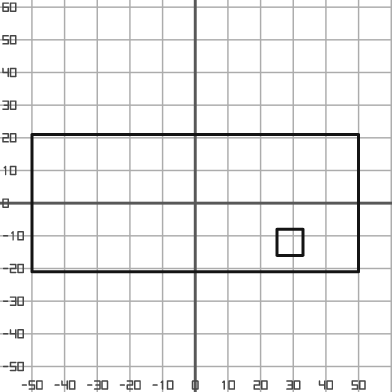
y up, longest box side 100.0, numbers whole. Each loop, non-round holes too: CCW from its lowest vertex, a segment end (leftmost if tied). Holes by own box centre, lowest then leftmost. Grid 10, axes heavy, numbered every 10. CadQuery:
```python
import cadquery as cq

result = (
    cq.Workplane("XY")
    .moveTo(-50.0, -21.0)
    .lineTo(50.0, -21.0)
    .lineTo(50.0, 21.0)
    .lineTo(-50.0, 21.0)
    .close()
    .moveTo(25.0, -16.0)
    .lineTo(33.0, -16.0)
    .lineTo(33.0, -8.0)
    .lineTo(25.0, -8.0)
    .close()
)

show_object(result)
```